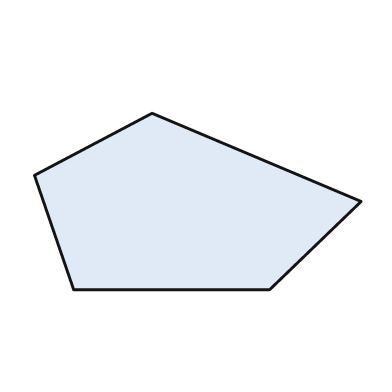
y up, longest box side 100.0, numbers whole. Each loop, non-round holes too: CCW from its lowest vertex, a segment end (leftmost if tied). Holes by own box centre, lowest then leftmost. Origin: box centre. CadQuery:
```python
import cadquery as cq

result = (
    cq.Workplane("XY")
    .moveTo(-38.0, -27.0)
    .lineTo(22.0, -27.0)
    .lineTo(50.0, 0.0)
    .lineTo(-14.0, 27.0)
    .lineTo(-50.0, 8.0)
    .close()
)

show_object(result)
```